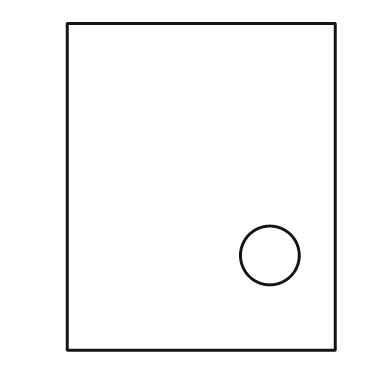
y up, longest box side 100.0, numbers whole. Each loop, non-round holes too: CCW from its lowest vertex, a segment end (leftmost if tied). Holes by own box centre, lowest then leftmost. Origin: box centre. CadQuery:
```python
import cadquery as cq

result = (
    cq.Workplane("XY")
    .moveTo(-41.0, -50.0)
    .lineTo(41.0, -50.0)
    .lineTo(41.0, 50.0)
    .lineTo(-41.0, 50.0)
    .close()
    .moveTo(21.0, -21.0)
    .circle(9.0)
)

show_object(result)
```